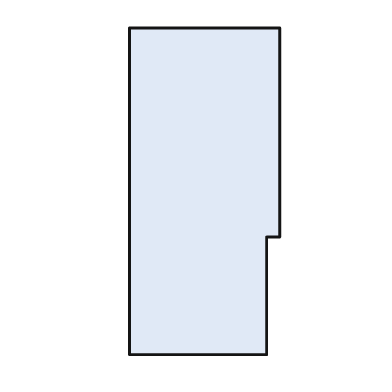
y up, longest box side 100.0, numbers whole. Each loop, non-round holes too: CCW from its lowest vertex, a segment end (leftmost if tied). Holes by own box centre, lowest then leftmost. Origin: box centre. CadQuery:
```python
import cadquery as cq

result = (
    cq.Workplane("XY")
    .moveTo(-23.0, -50.0)
    .lineTo(19.0, -50.0)
    .lineTo(19.0, -14.0)
    .lineTo(23.0, -14.0)
    .lineTo(23.0, 50.0)
    .lineTo(-23.0, 50.0)
    .close()
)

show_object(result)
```